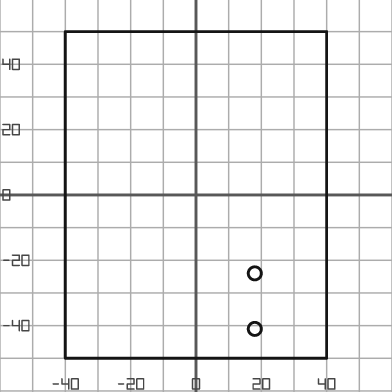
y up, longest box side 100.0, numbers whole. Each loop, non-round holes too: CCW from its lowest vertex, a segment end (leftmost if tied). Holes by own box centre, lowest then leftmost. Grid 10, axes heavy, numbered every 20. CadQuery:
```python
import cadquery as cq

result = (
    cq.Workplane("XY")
    .moveTo(-40.0, -50.0)
    .lineTo(40.0, -50.0)
    .lineTo(40.0, 50.0)
    .lineTo(-40.0, 50.0)
    .close()
    .moveTo(18.0, -41.0)
    .circle(2.0)
    .moveTo(18.0, -24.0)
    .circle(2.0)
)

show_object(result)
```